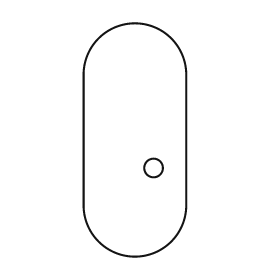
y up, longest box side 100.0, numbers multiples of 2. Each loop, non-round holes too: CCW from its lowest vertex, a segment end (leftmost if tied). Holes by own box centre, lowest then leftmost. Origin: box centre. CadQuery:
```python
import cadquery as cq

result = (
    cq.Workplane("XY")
    .moveTo(-22.0, -28.0)
    .threePointArc((0.0, -50.0), (22.0, -28.0))
    .lineTo(22.0, 28.0)
    .threePointArc((0.0, 50.0), (-22.0, 28.0))
    .close()
    .moveTo(8.0, -12.0)
    .circle(4.0)
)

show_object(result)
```